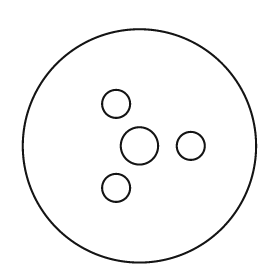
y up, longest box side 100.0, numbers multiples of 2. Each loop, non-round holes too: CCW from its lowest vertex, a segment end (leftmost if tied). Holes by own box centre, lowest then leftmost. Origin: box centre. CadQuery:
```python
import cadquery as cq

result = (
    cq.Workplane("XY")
    .moveTo(0.0, 0.0)
    .circle(50.0)
    .moveTo(-10.0, -18.0)
    .circle(6.0)
    .moveTo(0.0, 0.0)
    .circle(8.0)
    .moveTo(22.0, 0.0)
    .circle(6.0)
    .moveTo(-10.0, 18.0)
    .circle(6.0)
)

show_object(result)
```